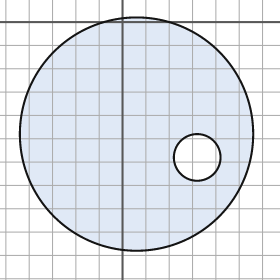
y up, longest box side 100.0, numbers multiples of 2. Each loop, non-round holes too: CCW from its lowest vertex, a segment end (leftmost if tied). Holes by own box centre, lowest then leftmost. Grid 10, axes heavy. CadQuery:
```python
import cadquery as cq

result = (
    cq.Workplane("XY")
    .moveTo(6.0, -48.0)
    .circle(50.0)
    .moveTo(32.0, -58.0)
    .circle(10.0)
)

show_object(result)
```